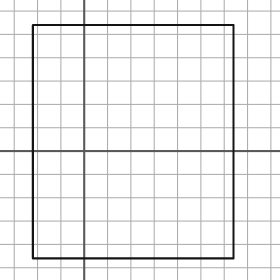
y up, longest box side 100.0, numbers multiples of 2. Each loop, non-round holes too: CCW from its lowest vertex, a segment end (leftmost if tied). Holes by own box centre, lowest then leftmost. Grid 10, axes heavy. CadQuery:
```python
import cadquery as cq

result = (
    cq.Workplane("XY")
    .moveTo(-22.0, -46.0)
    .lineTo(64.0, -46.0)
    .lineTo(64.0, 54.0)
    .lineTo(-22.0, 54.0)
    .close()
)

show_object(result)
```